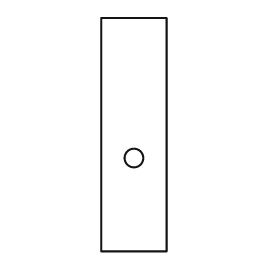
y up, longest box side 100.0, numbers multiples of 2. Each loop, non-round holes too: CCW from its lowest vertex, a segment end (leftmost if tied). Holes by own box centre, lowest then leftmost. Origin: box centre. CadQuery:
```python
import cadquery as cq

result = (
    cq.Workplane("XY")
    .moveTo(-14.0, -50.0)
    .lineTo(14.0, -50.0)
    .lineTo(14.0, 50.0)
    .lineTo(-14.0, 50.0)
    .close()
    .moveTo(0.0, -10.0)
    .circle(4.0)
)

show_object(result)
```